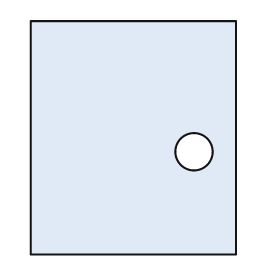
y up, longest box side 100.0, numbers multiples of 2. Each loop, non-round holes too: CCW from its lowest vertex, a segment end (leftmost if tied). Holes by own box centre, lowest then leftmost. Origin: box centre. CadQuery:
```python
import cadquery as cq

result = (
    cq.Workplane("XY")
    .moveTo(-44.0, -50.0)
    .lineTo(44.0, -50.0)
    .lineTo(44.0, 50.0)
    .lineTo(-44.0, 50.0)
    .close()
    .moveTo(26.0, -6.0)
    .circle(8.0)
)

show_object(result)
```